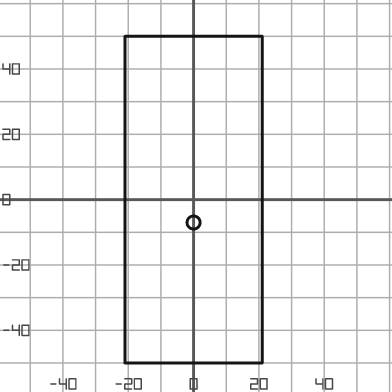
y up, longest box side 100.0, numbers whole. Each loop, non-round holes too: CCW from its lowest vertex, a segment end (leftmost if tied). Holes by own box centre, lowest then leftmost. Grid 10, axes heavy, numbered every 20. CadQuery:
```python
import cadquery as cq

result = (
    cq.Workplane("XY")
    .moveTo(-21.0, -50.0)
    .lineTo(21.0, -50.0)
    .lineTo(21.0, 50.0)
    .lineTo(-21.0, 50.0)
    .close()
    .moveTo(0.0, -7.0)
    .circle(2.0)
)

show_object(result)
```